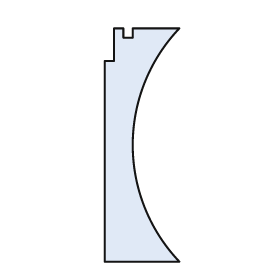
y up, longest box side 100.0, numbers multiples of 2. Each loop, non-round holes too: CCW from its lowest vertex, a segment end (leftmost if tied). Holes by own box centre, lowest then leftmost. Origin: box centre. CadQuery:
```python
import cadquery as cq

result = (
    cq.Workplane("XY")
    .moveTo(-16.0, -50.0)
    .lineTo(16.0, -50.0)
    .threePointArc((-4.0, 0.0), (16.0, 50.0))
    .lineTo(-4.0, 50.0)
    .lineTo(-4.0, 46.0)
    .lineTo(-8.0, 46.0)
    .lineTo(-8.0, 50.0)
    .lineTo(-12.0, 50.0)
    .lineTo(-12.0, 36.0)
    .lineTo(-16.0, 36.0)
    .close()
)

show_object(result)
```